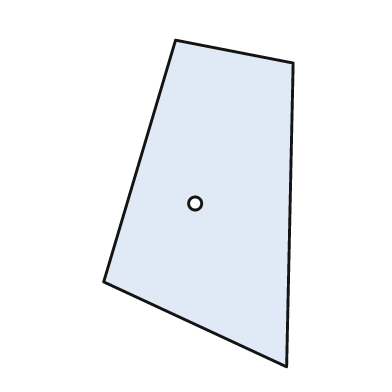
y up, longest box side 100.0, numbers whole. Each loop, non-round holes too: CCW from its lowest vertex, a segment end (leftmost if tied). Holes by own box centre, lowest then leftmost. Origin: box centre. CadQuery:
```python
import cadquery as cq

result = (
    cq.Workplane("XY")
    .moveTo(27.0, -50.0)
    .lineTo(29.0, 43.0)
    .lineTo(-7.0, 50.0)
    .lineTo(-29.0, -24.0)
    .close()
    .moveTo(-1.0, 0.0)
    .circle(2.0)
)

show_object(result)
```